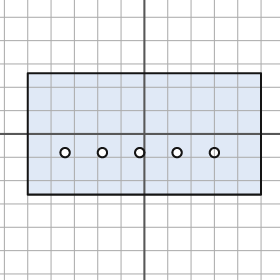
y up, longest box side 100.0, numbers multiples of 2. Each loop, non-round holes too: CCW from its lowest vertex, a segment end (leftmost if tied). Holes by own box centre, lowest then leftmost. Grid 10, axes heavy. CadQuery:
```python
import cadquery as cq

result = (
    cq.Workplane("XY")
    .moveTo(-50.0, -26.0)
    .lineTo(50.0, -26.0)
    .lineTo(50.0, 26.0)
    .lineTo(-50.0, 26.0)
    .close()
    .moveTo(-34.0, -8.0)
    .circle(2.0)
    .moveTo(-18.0, -8.0)
    .circle(2.0)
    .moveTo(-2.0, -8.0)
    .circle(2.0)
    .moveTo(14.0, -8.0)
    .circle(2.0)
    .moveTo(30.0, -8.0)
    .circle(2.0)
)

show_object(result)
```